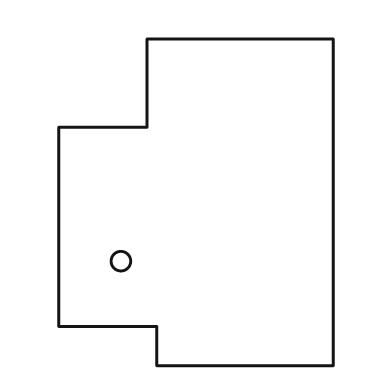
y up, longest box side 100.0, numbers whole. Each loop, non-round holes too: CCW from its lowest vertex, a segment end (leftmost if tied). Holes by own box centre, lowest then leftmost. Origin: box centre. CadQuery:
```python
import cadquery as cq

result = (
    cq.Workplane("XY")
    .moveTo(-12.0, -50.0)
    .lineTo(42.0, -50.0)
    .lineTo(42.0, 50.0)
    .lineTo(-15.0, 50.0)
    .lineTo(-15.0, 23.0)
    .lineTo(-42.0, 23.0)
    .lineTo(-42.0, -38.0)
    .lineTo(-12.0, -38.0)
    .close()
    .moveTo(-23.0, -18.0)
    .circle(3.0)
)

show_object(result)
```